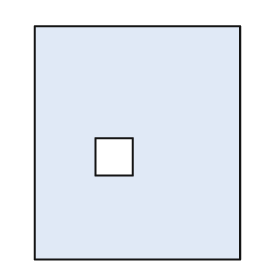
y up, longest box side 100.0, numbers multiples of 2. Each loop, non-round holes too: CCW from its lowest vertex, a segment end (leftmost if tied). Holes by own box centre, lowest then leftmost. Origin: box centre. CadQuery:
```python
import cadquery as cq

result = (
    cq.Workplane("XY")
    .moveTo(-44.0, -50.0)
    .lineTo(44.0, -50.0)
    .lineTo(44.0, 50.0)
    .lineTo(-44.0, 50.0)
    .close()
    .moveTo(-18.0, -14.0)
    .lineTo(-2.0, -14.0)
    .lineTo(-2.0, 2.0)
    .lineTo(-18.0, 2.0)
    .close()
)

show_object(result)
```